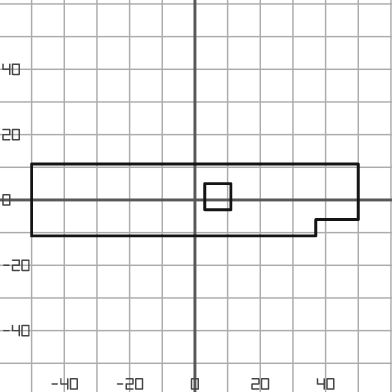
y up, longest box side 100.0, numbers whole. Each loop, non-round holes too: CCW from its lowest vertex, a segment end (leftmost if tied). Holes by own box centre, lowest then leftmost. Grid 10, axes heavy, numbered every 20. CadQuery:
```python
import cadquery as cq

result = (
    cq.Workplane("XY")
    .moveTo(-50.0, -11.0)
    .lineTo(37.0, -11.0)
    .lineTo(37.0, -6.0)
    .lineTo(50.0, -6.0)
    .lineTo(50.0, 11.0)
    .lineTo(-50.0, 11.0)
    .close()
    .moveTo(3.0, -3.0)
    .lineTo(11.0, -3.0)
    .lineTo(11.0, 5.0)
    .lineTo(3.0, 5.0)
    .close()
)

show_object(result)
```